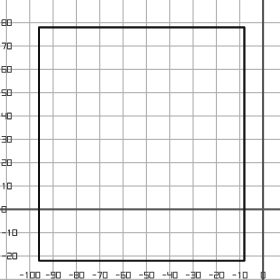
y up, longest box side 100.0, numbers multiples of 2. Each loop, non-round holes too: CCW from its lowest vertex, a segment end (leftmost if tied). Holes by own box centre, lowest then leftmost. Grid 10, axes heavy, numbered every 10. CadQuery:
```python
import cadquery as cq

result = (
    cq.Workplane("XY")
    .moveTo(-96.0, -22.0)
    .lineTo(-8.0, -22.0)
    .lineTo(-8.0, 78.0)
    .lineTo(-96.0, 78.0)
    .close()
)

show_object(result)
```